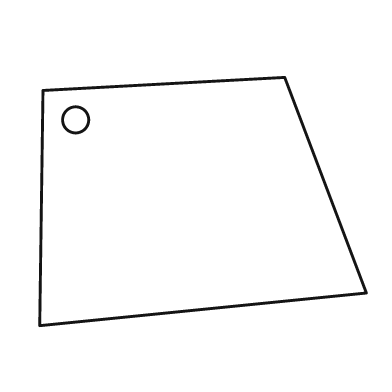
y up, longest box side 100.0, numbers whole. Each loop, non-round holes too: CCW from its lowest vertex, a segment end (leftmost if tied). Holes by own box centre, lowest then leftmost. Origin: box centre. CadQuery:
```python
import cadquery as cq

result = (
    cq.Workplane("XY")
    .moveTo(-50.0, -38.0)
    .lineTo(50.0, -28.0)
    .lineTo(25.0, 38.0)
    .lineTo(-49.0, 34.0)
    .close()
    .moveTo(-39.0, 25.0)
    .circle(4.0)
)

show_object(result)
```